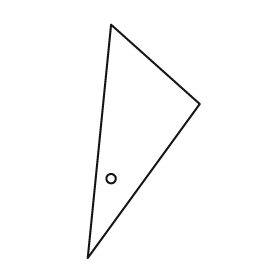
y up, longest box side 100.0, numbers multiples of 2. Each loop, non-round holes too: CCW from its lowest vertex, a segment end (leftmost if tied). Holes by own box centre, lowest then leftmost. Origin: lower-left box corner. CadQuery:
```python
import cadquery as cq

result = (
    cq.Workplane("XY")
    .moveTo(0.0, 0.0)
    .lineTo(48.0, 66.0)
    .lineTo(10.0, 100.0)
    .close()
    .moveTo(10.0, 34.0)
    .circle(2.0)
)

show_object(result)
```